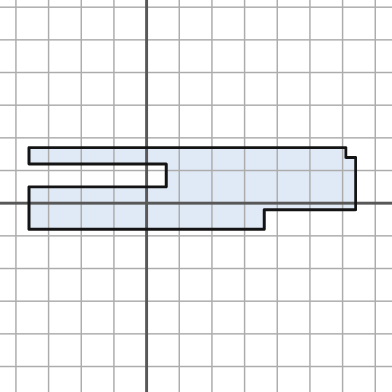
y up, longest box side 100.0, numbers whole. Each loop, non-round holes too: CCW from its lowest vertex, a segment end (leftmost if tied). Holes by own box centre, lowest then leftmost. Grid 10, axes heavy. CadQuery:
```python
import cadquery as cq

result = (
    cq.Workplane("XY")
    .moveTo(-36.0, -8.0)
    .lineTo(36.0, -8.0)
    .lineTo(36.0, -2.0)
    .lineTo(64.0, -2.0)
    .lineTo(64.0, 14.0)
    .lineTo(61.0, 14.0)
    .lineTo(61.0, 17.0)
    .lineTo(-36.0, 17.0)
    .lineTo(-36.0, 12.0)
    .lineTo(6.0, 12.0)
    .lineTo(6.0, 5.0)
    .lineTo(-36.0, 5.0)
    .close()
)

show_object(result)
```